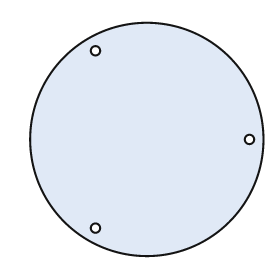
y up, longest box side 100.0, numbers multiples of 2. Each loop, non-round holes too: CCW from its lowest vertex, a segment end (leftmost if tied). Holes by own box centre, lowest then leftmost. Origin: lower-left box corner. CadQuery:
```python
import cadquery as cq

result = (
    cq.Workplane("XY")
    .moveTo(50.0, 50.0)
    .circle(50.0)
    .moveTo(28.0, 12.0)
    .circle(2.0)
    .moveTo(94.0, 50.0)
    .circle(2.0)
    .moveTo(28.0, 88.0)
    .circle(2.0)
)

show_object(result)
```